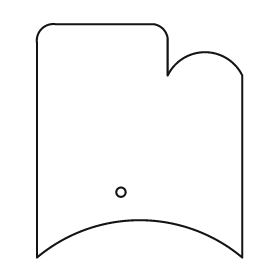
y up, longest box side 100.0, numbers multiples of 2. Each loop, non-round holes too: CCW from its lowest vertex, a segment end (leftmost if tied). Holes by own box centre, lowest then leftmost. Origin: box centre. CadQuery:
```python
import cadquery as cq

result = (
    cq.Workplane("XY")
    .moveTo(-44.0, -50.0)
    .threePointArc((0.0, -34.0), (44.0, -50.0))
    .lineTo(44.0, 28.0)
    .threePointArc((28.0, 38.0), (12.0, 28.0))
    .lineTo(12.0, 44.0)
    .threePointArc((10.0, 48.0), (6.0, 50.0))
    .lineTo(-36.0, 50.0)
    .threePointArc((-42.0, 48.0), (-44.0, 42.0))
    .close()
    .moveTo(-8.0, -22.0)
    .circle(2.0)
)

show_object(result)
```